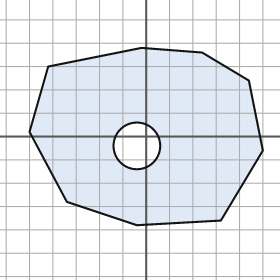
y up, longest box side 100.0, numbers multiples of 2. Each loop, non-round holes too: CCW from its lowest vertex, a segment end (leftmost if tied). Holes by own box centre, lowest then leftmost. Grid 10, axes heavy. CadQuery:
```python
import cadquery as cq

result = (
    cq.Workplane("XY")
    .moveTo(-4.0, -38.0)
    .lineTo(32.0, -36.0)
    .lineTo(50.0, -6.0)
    .lineTo(44.0, 24.0)
    .lineTo(24.0, 36.0)
    .lineTo(-2.0, 38.0)
    .lineTo(-42.0, 30.0)
    .lineTo(-50.0, 2.0)
    .lineTo(-34.0, -28.0)
    .close()
    .moveTo(-4.0, -4.0)
    .circle(10.0)
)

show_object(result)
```